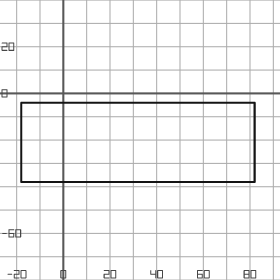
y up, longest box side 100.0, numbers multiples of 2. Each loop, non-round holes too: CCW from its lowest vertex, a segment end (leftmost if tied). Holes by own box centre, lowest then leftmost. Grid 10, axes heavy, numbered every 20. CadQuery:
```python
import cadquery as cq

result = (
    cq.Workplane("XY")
    .moveTo(-18.0, -38.0)
    .lineTo(82.0, -38.0)
    .lineTo(82.0, -4.0)
    .lineTo(-18.0, -4.0)
    .close()
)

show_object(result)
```